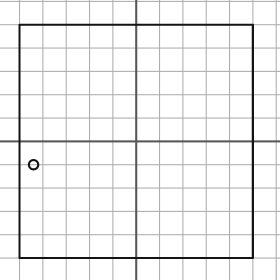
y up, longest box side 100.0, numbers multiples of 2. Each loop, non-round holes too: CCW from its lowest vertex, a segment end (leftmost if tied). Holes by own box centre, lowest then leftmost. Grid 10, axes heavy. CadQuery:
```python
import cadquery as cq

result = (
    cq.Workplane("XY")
    .moveTo(-50.0, -50.0)
    .lineTo(50.0, -50.0)
    .lineTo(50.0, 50.0)
    .lineTo(-50.0, 50.0)
    .close()
    .moveTo(-44.0, -10.0)
    .circle(2.0)
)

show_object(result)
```